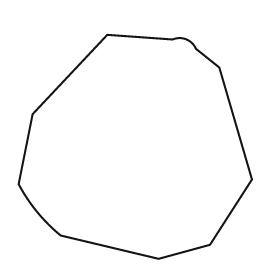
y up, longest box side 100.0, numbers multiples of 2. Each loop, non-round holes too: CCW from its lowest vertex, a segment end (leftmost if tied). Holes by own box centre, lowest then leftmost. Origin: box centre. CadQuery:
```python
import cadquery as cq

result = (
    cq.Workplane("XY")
    .moveTo(10.0, -48.0)
    .lineTo(32.0, -42.0)
    .lineTo(50.0, -14.0)
    .lineTo(36.0, 34.0)
    .lineTo(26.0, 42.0)
    .threePointArc((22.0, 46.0), (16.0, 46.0))
    .lineTo(-12.0, 48.0)
    .lineTo(-44.0, 14.0)
    .lineTo(-50.0, -16.0)
    .threePointArc((-42.0, -28.0), (-32.0, -38.0))
    .close()
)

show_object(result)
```